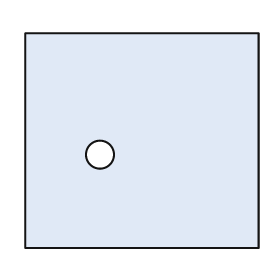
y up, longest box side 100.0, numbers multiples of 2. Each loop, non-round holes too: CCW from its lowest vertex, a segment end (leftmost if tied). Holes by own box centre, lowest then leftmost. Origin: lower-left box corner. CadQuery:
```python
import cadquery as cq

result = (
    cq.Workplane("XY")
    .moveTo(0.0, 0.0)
    .lineTo(100.0, 0.0)
    .lineTo(100.0, 92.0)
    .lineTo(0.0, 92.0)
    .close()
    .moveTo(32.0, 40.0)
    .circle(6.0)
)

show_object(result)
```